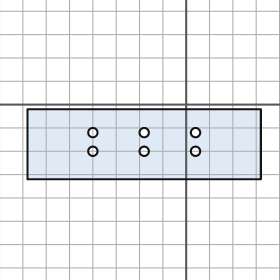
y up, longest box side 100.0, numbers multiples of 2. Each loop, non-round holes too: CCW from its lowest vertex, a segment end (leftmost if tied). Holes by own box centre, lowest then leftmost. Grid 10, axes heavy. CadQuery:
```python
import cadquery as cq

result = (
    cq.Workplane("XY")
    .moveTo(-68.0, -32.0)
    .lineTo(32.0, -32.0)
    .lineTo(32.0, -2.0)
    .lineTo(-68.0, -2.0)
    .close()
    .moveTo(-40.0, -20.0)
    .circle(2.0)
    .moveTo(-18.0, -20.0)
    .circle(2.0)
    .moveTo(4.0, -20.0)
    .circle(2.0)
    .moveTo(-40.0, -12.0)
    .circle(2.0)
    .moveTo(-18.0, -12.0)
    .circle(2.0)
    .moveTo(4.0, -12.0)
    .circle(2.0)
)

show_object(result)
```